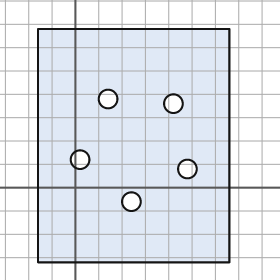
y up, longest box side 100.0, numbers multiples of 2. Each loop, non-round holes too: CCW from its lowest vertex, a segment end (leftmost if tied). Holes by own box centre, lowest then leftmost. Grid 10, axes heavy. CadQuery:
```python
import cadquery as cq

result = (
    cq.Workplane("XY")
    .moveTo(-16.0, -32.0)
    .lineTo(66.0, -32.0)
    .lineTo(66.0, 68.0)
    .lineTo(-16.0, 68.0)
    .close()
    .moveTo(24.0, -6.0)
    .circle(4.0)
    .moveTo(48.0, 8.0)
    .circle(4.0)
    .moveTo(2.0, 12.0)
    .circle(4.0)
    .moveTo(42.0, 36.0)
    .circle(4.0)
    .moveTo(14.0, 38.0)
    .circle(4.0)
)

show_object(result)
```